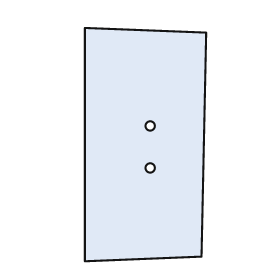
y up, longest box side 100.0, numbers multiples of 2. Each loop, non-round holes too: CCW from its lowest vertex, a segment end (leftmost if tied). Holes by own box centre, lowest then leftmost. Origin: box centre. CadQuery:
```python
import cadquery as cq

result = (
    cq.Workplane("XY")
    .moveTo(-26.0, -50.0)
    .lineTo(24.0, -48.0)
    .lineTo(26.0, 48.0)
    .lineTo(-26.0, 50.0)
    .close()
    .moveTo(2.0, -10.0)
    .circle(2.0)
    .moveTo(2.0, 8.0)
    .circle(2.0)
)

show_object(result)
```